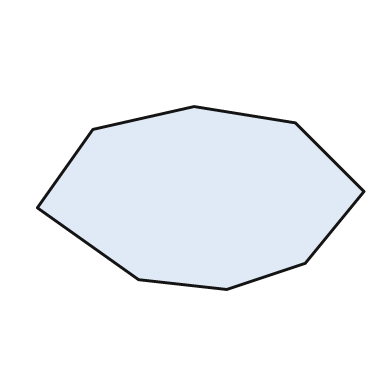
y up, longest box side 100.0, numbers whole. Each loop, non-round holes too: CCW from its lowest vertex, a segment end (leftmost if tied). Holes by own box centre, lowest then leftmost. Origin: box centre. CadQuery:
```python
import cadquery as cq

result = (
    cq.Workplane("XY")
    .moveTo(8.0, -28.0)
    .lineTo(32.0, -20.0)
    .lineTo(50.0, 2.0)
    .lineTo(29.0, 23.0)
    .lineTo(-2.0, 28.0)
    .lineTo(-33.0, 21.0)
    .lineTo(-50.0, -3.0)
    .lineTo(-19.0, -25.0)
    .close()
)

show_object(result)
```